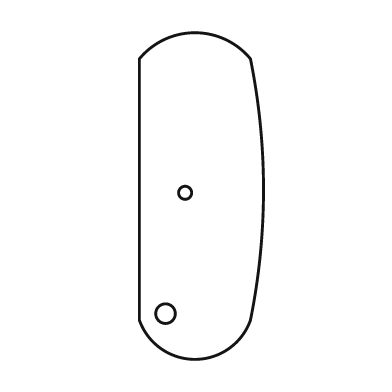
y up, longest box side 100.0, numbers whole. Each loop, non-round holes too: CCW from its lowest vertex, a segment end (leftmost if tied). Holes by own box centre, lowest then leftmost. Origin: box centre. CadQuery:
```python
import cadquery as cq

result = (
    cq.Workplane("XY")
    .moveTo(-19.0, -38.0)
    .threePointArc((-2.0, -50.0), (15.0, -38.0))
    .threePointArc((19.0, 2.0), (15.0, 42.0))
    .threePointArc((-2.0, 50.0), (-19.0, 42.0))
    .close()
    .moveTo(-11.0, -36.0)
    .circle(3.0)
    .moveTo(-5.0, 1.0)
    .circle(2.0)
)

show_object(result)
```